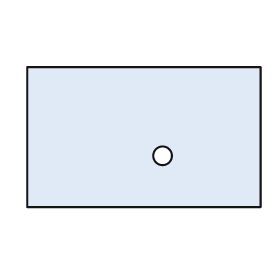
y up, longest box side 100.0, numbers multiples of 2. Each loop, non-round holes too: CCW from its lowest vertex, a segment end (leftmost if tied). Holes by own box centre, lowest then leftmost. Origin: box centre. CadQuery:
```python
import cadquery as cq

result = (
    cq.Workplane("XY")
    .moveTo(-50.0, -30.0)
    .lineTo(50.0, -30.0)
    .lineTo(50.0, 30.0)
    .lineTo(-50.0, 30.0)
    .close()
    .moveTo(8.0, -8.0)
    .circle(4.0)
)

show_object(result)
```